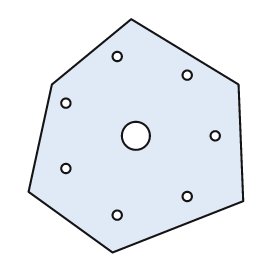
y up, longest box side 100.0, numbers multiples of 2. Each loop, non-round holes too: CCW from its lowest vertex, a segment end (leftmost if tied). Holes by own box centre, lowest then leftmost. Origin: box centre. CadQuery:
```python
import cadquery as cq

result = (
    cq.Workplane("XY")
    .moveTo(-10.0, -50.0)
    .lineTo(46.0, -28.0)
    .lineTo(44.0, 22.0)
    .lineTo(-2.0, 50.0)
    .lineTo(-36.0, 22.0)
    .lineTo(-46.0, -24.0)
    .close()
    .moveTo(-8.0, -34.0)
    .circle(2.0)
    .moveTo(22.0, -26.0)
    .circle(2.0)
    .moveTo(-30.0, -14.0)
    .circle(2.0)
    .moveTo(0.0, 0.0)
    .circle(6.0)
    .moveTo(34.0, 0.0)
    .circle(2.0)
    .moveTo(-30.0, 14.0)
    .circle(2.0)
    .moveTo(22.0, 26.0)
    .circle(2.0)
    .moveTo(-8.0, 34.0)
    .circle(2.0)
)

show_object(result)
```